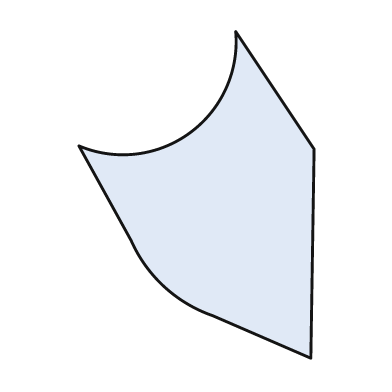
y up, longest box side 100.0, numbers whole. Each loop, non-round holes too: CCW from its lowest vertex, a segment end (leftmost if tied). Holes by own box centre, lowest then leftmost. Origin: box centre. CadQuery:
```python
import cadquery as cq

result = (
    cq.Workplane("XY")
    .moveTo(35.0, -50.0)
    .lineTo(36.0, 14.0)
    .lineTo(12.0, 50.0)
    .threePointArc((-2.0, 19.0), (-36.0, 15.0))
    .lineTo(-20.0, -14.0)
    .threePointArc((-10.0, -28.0), (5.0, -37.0))
    .close()
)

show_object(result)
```